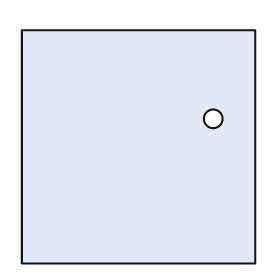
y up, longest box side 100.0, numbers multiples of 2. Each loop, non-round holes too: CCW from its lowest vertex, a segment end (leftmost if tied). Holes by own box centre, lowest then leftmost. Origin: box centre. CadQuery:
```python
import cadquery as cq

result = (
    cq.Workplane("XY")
    .moveTo(-50.0, -50.0)
    .lineTo(50.0, -50.0)
    .lineTo(50.0, 50.0)
    .lineTo(-50.0, 50.0)
    .close()
    .moveTo(32.0, 12.0)
    .circle(4.0)
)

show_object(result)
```